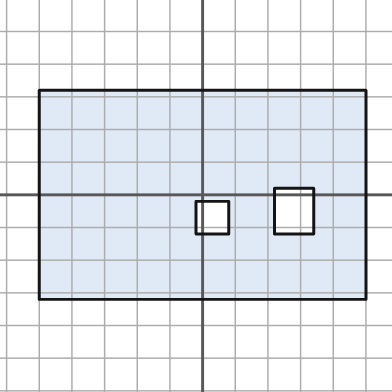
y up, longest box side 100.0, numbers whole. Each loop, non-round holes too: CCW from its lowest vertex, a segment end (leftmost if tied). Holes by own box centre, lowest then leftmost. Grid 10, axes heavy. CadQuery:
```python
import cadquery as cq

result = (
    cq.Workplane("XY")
    .moveTo(-50.0, -32.0)
    .lineTo(50.0, -32.0)
    .lineTo(50.0, 32.0)
    .lineTo(-50.0, 32.0)
    .close()
    .moveTo(-2.0, -12.0)
    .lineTo(8.0, -12.0)
    .lineTo(8.0, -2.0)
    .lineTo(-2.0, -2.0)
    .close()
    .moveTo(22.0, -12.0)
    .lineTo(34.0, -12.0)
    .lineTo(34.0, 2.0)
    .lineTo(22.0, 2.0)
    .close()
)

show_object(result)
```